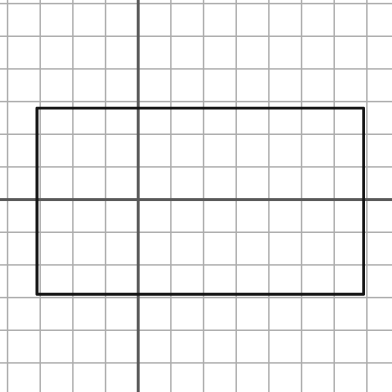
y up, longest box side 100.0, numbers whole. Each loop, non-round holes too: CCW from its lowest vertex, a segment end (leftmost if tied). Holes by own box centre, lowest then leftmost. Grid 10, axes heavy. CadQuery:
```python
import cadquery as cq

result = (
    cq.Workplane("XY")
    .moveTo(-31.0, -29.0)
    .lineTo(69.0, -29.0)
    .lineTo(69.0, 28.0)
    .lineTo(-31.0, 28.0)
    .close()
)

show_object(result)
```